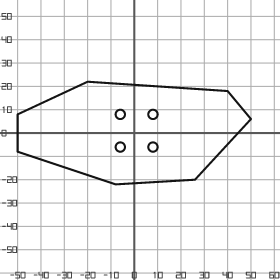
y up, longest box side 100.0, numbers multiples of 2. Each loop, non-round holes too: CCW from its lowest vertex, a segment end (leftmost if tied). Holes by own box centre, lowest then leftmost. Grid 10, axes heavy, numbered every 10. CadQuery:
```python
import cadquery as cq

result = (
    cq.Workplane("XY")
    .moveTo(-8.0, -22.0)
    .lineTo(26.0, -20.0)
    .lineTo(50.0, 6.0)
    .lineTo(40.0, 18.0)
    .lineTo(-20.0, 22.0)
    .lineTo(-50.0, 8.0)
    .lineTo(-50.0, -8.0)
    .close()
    .moveTo(-6.0, -6.0)
    .circle(2.0)
    .moveTo(8.0, -6.0)
    .circle(2.0)
    .moveTo(-6.0, 8.0)
    .circle(2.0)
    .moveTo(8.0, 8.0)
    .circle(2.0)
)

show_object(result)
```